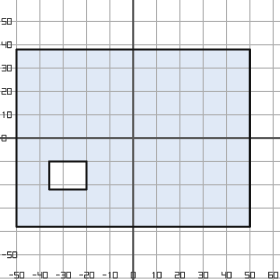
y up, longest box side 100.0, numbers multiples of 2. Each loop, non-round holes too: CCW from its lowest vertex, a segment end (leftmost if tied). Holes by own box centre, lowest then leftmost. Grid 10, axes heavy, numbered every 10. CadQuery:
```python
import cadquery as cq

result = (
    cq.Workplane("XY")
    .moveTo(-50.0, -38.0)
    .lineTo(50.0, -38.0)
    .lineTo(50.0, 38.0)
    .lineTo(-50.0, 38.0)
    .close()
    .moveTo(-36.0, -22.0)
    .lineTo(-20.0, -22.0)
    .lineTo(-20.0, -10.0)
    .lineTo(-36.0, -10.0)
    .close()
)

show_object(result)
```